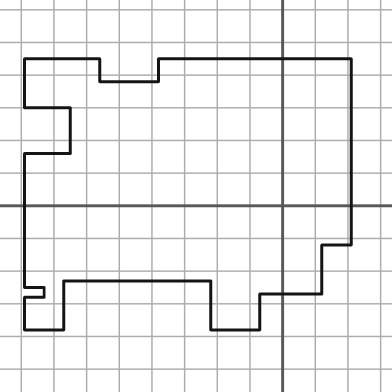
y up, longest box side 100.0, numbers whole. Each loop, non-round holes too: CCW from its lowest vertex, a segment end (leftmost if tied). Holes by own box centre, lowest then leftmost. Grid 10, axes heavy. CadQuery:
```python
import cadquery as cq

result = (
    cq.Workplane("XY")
    .moveTo(-79.0, -38.0)
    .lineTo(-67.0, -38.0)
    .lineTo(-67.0, -23.0)
    .lineTo(-22.0, -23.0)
    .lineTo(-22.0, -38.0)
    .lineTo(-7.0, -38.0)
    .lineTo(-7.0, -27.0)
    .lineTo(12.0, -27.0)
    .lineTo(12.0, -12.0)
    .lineTo(21.0, -12.0)
    .lineTo(21.0, 45.0)
    .lineTo(-38.0, 45.0)
    .lineTo(-38.0, 38.0)
    .lineTo(-56.0, 38.0)
    .lineTo(-56.0, 45.0)
    .lineTo(-79.0, 45.0)
    .lineTo(-79.0, 30.0)
    .lineTo(-65.0, 30.0)
    .lineTo(-65.0, 16.0)
    .lineTo(-79.0, 16.0)
    .lineTo(-79.0, -25.0)
    .lineTo(-73.0, -25.0)
    .lineTo(-73.0, -28.0)
    .lineTo(-79.0, -28.0)
    .close()
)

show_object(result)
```